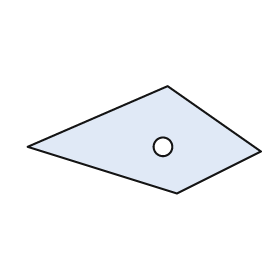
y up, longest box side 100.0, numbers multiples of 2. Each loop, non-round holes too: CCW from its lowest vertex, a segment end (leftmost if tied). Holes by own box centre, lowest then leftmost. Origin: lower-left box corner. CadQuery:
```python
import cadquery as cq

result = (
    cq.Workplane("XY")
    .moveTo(64.0, 0.0)
    .lineTo(100.0, 18.0)
    .lineTo(60.0, 46.0)
    .lineTo(0.0, 20.0)
    .close()
    .moveTo(58.0, 20.0)
    .circle(4.0)
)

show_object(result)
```